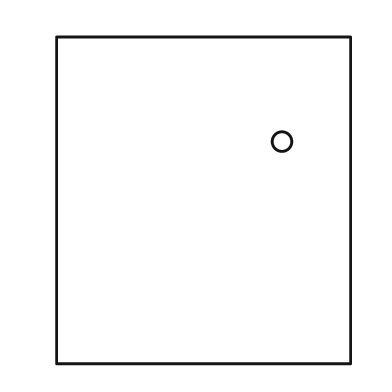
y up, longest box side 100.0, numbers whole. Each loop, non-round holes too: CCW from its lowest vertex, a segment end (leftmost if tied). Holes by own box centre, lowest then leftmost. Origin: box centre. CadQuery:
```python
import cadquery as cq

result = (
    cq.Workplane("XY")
    .moveTo(-45.0, -50.0)
    .lineTo(45.0, -50.0)
    .lineTo(45.0, 50.0)
    .lineTo(-45.0, 50.0)
    .close()
    .moveTo(24.0, 18.0)
    .circle(3.0)
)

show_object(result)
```